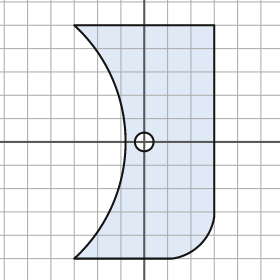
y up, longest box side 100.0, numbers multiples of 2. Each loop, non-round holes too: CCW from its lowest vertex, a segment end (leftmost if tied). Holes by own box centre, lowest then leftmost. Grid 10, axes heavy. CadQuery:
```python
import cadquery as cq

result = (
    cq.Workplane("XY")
    .moveTo(-30.0, -50.0)
    .lineTo(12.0, -50.0)
    .threePointArc((24.0, -44.0), (30.0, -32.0))
    .lineTo(30.0, 50.0)
    .lineTo(-30.0, 50.0)
    .threePointArc((-8.0, 0.0), (-30.0, -50.0))
    .close()
    .moveTo(0.0, 0.0)
    .circle(4.0)
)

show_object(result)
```